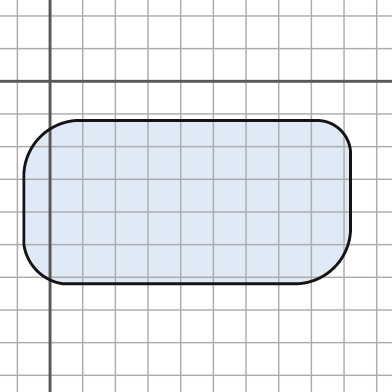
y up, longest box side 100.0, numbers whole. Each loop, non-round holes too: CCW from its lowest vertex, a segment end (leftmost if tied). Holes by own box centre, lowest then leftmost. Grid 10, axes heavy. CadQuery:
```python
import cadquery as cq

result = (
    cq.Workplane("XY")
    .moveTo(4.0, -62.0)
    .lineTo(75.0, -62.0)
    .threePointArc((87.0, -57.0), (92.0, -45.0))
    .lineTo(92.0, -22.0)
    .threePointArc((89.0, -15.0), (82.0, -12.0))
    .lineTo(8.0, -12.0)
    .threePointArc((-3.0, -17.0), (-8.0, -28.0))
    .lineTo(-8.0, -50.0)
    .threePointArc((-4.0, -58.0), (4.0, -62.0))
    .close()
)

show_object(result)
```